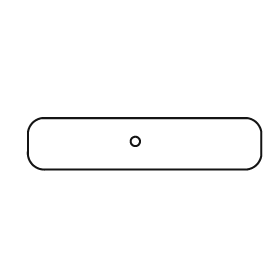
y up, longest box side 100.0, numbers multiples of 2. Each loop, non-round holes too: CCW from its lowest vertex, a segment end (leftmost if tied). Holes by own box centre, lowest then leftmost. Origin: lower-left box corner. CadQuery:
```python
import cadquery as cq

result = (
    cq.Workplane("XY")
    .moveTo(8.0, 0.0)
    .lineTo(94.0, 0.0)
    .threePointArc((98.0, 2.0), (100.0, 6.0))
    .lineTo(100.0, 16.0)
    .threePointArc((98.0, 20.0), (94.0, 22.0))
    .lineTo(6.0, 22.0)
    .threePointArc((2.0, 20.0), (0.0, 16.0))
    .lineTo(0.0, 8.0)
    .threePointArc((2.0, 2.0), (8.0, 0.0))
    .close()
    .moveTo(46.0, 12.0)
    .circle(2.0)
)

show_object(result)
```